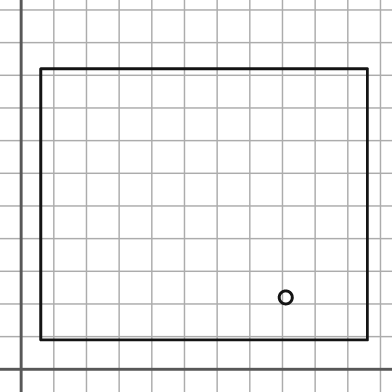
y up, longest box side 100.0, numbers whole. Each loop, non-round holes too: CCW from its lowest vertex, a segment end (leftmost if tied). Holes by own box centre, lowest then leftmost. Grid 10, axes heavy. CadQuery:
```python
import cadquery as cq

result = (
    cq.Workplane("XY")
    .moveTo(6.0, 9.0)
    .lineTo(106.0, 9.0)
    .lineTo(106.0, 92.0)
    .lineTo(6.0, 92.0)
    .close()
    .moveTo(81.0, 22.0)
    .circle(2.0)
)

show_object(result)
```